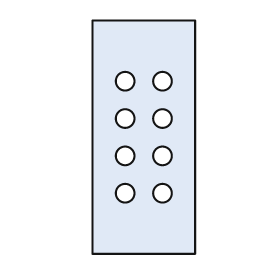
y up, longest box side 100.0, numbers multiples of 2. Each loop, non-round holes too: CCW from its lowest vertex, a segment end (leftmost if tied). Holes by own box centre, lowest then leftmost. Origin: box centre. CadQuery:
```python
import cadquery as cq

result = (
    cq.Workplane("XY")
    .moveTo(-22.0, -50.0)
    .lineTo(22.0, -50.0)
    .lineTo(22.0, 50.0)
    .lineTo(-22.0, 50.0)
    .close()
    .moveTo(-8.0, -24.0)
    .circle(4.0)
    .moveTo(8.0, -24.0)
    .circle(4.0)
    .moveTo(-8.0, -8.0)
    .circle(4.0)
    .moveTo(8.0, -8.0)
    .circle(4.0)
    .moveTo(-8.0, 8.0)
    .circle(4.0)
    .moveTo(8.0, 8.0)
    .circle(4.0)
    .moveTo(-8.0, 24.0)
    .circle(4.0)
    .moveTo(8.0, 24.0)
    .circle(4.0)
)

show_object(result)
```